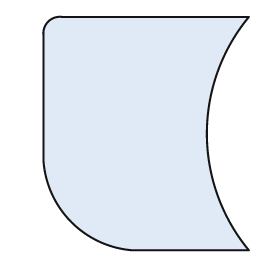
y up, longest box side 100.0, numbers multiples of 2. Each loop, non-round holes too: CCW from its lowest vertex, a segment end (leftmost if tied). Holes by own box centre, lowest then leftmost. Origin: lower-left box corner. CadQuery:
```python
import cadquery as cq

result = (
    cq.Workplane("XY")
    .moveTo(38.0, 0.0)
    .lineTo(88.0, 0.0)
    .threePointArc((70.0, 50.0), (88.0, 100.0))
    .lineTo(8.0, 100.0)
    .threePointArc((2.0, 98.0), (0.0, 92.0))
    .lineTo(0.0, 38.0)
    .threePointArc((12.0, 12.0), (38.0, 0.0))
    .close()
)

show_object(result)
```